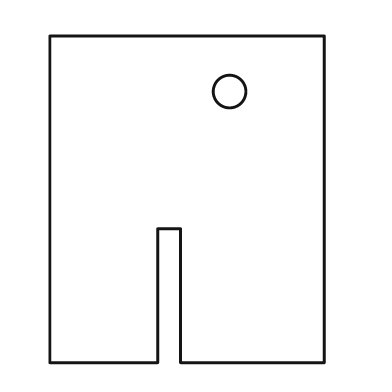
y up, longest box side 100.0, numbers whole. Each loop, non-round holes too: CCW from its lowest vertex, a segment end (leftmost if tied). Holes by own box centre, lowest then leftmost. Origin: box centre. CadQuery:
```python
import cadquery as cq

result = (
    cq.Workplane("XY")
    .moveTo(-42.0, -50.0)
    .lineTo(-9.0, -50.0)
    .lineTo(-9.0, -9.0)
    .lineTo(-2.0, -9.0)
    .lineTo(-2.0, -50.0)
    .lineTo(42.0, -50.0)
    .lineTo(42.0, 50.0)
    .lineTo(-42.0, 50.0)
    .close()
    .moveTo(13.0, 33.0)
    .circle(5.0)
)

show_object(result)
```